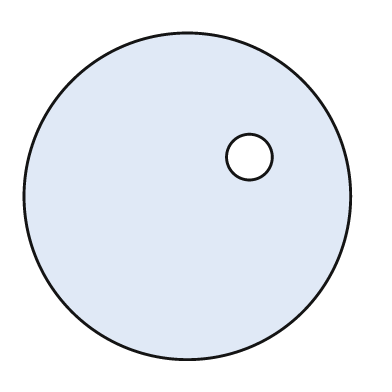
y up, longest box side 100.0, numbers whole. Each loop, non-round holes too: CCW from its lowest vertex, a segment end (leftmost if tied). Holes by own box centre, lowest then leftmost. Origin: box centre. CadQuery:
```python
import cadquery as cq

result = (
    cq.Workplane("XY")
    .moveTo(0.0, 0.0)
    .circle(50.0)
    .moveTo(19.0, 12.0)
    .circle(7.0)
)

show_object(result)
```